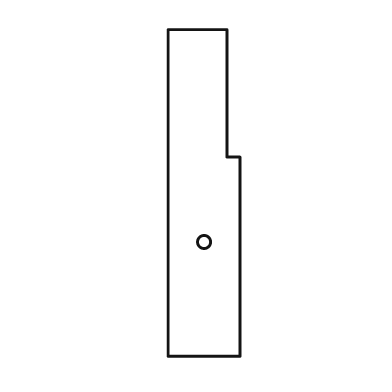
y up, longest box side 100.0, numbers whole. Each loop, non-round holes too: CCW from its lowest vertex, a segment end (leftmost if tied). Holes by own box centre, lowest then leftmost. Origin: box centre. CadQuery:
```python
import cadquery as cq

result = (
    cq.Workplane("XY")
    .moveTo(-11.0, -50.0)
    .lineTo(11.0, -50.0)
    .lineTo(11.0, 11.0)
    .lineTo(7.0, 11.0)
    .lineTo(7.0, 50.0)
    .lineTo(-11.0, 50.0)
    .close()
    .moveTo(0.0, -15.0)
    .circle(2.0)
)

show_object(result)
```